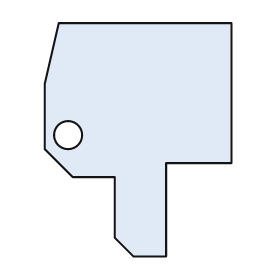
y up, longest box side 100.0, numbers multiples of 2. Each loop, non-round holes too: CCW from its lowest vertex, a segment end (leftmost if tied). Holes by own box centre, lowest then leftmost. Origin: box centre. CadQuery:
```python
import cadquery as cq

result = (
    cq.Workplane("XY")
    .moveTo(-2.0, -50.0)
    .lineTo(12.0, -50.0)
    .lineTo(12.0, -10.0)
    .lineTo(40.0, -10.0)
    .lineTo(40.0, 50.0)
    .lineTo(-34.0, 50.0)
    .lineTo(-40.0, 24.0)
    .lineTo(-40.0, -4.0)
    .lineTo(-28.0, -16.0)
    .lineTo(-10.0, -16.0)
    .lineTo(-10.0, -42.0)
    .close()
    .moveTo(-30.0, 2.0)
    .circle(6.0)
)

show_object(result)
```